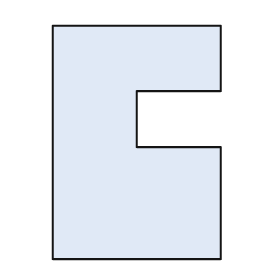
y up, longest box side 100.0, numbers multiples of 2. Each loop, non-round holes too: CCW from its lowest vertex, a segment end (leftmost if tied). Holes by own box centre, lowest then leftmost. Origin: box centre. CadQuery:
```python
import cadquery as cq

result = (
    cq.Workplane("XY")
    .moveTo(-36.0, -50.0)
    .lineTo(36.0, -50.0)
    .lineTo(36.0, -2.0)
    .lineTo(0.0, -2.0)
    .lineTo(0.0, 22.0)
    .lineTo(36.0, 22.0)
    .lineTo(36.0, 50.0)
    .lineTo(-36.0, 50.0)
    .close()
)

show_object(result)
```